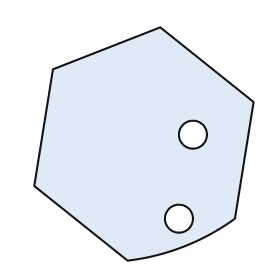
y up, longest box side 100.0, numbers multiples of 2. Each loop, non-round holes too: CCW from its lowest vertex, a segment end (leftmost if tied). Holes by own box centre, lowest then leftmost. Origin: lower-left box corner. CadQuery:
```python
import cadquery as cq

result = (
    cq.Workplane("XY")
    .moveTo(40.0, 0.0)
    .threePointArc((64.0, 6.0), (86.0, 18.0))
    .lineTo(94.0, 68.0)
    .lineTo(54.0, 100.0)
    .lineTo(8.0, 82.0)
    .lineTo(0.0, 32.0)
    .close()
    .moveTo(62.0, 18.0)
    .circle(6.0)
    .moveTo(68.0, 54.0)
    .circle(6.0)
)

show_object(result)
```